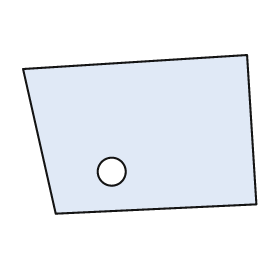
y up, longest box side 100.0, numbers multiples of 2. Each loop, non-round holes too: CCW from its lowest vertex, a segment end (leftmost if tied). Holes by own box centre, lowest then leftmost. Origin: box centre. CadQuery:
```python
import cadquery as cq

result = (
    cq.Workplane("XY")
    .moveTo(-36.0, -34.0)
    .lineTo(50.0, -30.0)
    .lineTo(46.0, 34.0)
    .lineTo(-50.0, 28.0)
    .close()
    .moveTo(-12.0, -16.0)
    .circle(6.0)
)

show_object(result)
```